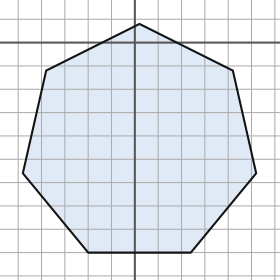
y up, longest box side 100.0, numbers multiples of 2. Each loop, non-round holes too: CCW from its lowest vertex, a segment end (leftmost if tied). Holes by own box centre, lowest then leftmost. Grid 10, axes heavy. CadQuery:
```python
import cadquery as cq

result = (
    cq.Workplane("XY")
    .moveTo(-20.0, -90.0)
    .lineTo(24.0, -90.0)
    .lineTo(52.0, -56.0)
    .lineTo(42.0, -12.0)
    .lineTo(2.0, 8.0)
    .lineTo(-38.0, -12.0)
    .lineTo(-48.0, -56.0)
    .close()
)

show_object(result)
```